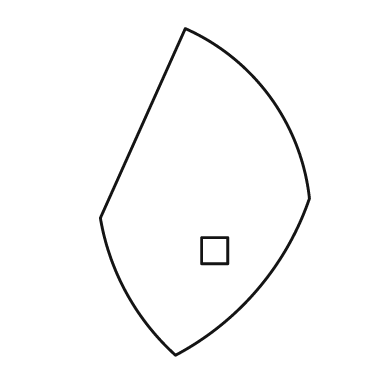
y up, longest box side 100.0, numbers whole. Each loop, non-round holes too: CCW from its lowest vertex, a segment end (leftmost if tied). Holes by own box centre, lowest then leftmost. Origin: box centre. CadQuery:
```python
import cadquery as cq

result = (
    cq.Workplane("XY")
    .moveTo(-9.0, -50.0)
    .threePointArc((16.0, -30.0), (32.0, -2.0))
    .threePointArc((20.0, 29.0), (-6.0, 50.0))
    .lineTo(-32.0, -8.0)
    .threePointArc((-24.0, -31.0), (-9.0, -50.0))
    .close()
    .moveTo(-1.0, -22.0)
    .lineTo(7.0, -22.0)
    .lineTo(7.0, -14.0)
    .lineTo(-1.0, -14.0)
    .close()
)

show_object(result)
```